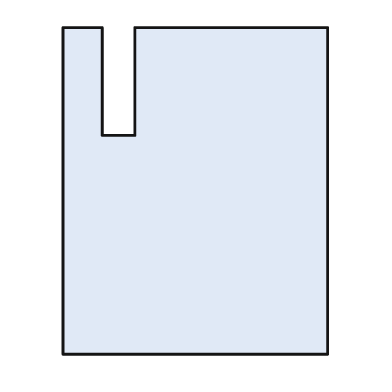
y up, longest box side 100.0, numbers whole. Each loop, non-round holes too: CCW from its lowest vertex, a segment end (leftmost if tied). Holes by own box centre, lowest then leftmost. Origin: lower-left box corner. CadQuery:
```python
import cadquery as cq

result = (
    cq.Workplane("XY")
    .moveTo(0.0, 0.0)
    .lineTo(81.0, 0.0)
    .lineTo(81.0, 100.0)
    .lineTo(22.0, 100.0)
    .lineTo(22.0, 67.0)
    .lineTo(12.0, 67.0)
    .lineTo(12.0, 100.0)
    .lineTo(0.0, 100.0)
    .close()
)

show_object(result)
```